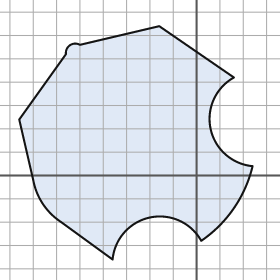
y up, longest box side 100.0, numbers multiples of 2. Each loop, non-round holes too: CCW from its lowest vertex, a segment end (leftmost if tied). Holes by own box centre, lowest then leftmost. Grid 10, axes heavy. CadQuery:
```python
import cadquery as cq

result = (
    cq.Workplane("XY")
    .moveTo(-36.0, -36.0)
    .threePointArc((-20.0, -18.0), (2.0, -28.0))
    .threePointArc((16.0, -14.0), (24.0, 4.0))
    .threePointArc((6.0, 20.0), (16.0, 42.0))
    .lineTo(-16.0, 64.0)
    .lineTo(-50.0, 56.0)
    .threePointArc((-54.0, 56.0), (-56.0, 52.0))
    .lineTo(-76.0, 24.0)
    .lineTo(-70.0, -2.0)
    .threePointArc((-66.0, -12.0), (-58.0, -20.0))
    .close()
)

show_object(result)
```